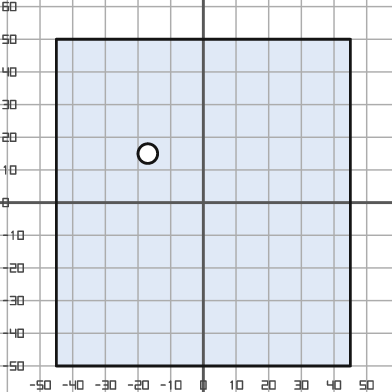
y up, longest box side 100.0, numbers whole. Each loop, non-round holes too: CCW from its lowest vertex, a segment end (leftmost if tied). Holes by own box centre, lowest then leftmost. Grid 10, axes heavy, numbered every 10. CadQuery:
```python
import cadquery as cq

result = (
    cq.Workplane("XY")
    .moveTo(-45.0, -50.0)
    .lineTo(45.0, -50.0)
    .lineTo(45.0, 50.0)
    .lineTo(-45.0, 50.0)
    .close()
    .moveTo(-17.0, 15.0)
    .circle(3.0)
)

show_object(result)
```